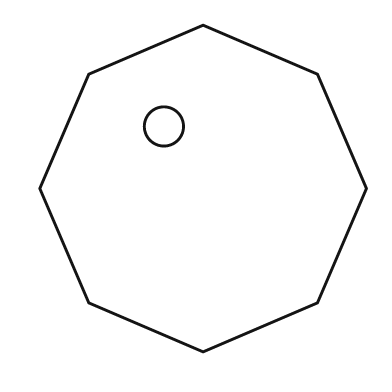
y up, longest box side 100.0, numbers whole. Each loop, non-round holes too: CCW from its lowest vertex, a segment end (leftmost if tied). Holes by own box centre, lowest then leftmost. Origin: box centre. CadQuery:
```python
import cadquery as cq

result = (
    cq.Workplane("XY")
    .moveTo(0.0, -50.0)
    .lineTo(35.0, -35.0)
    .lineTo(50.0, 0.0)
    .lineTo(35.0, 35.0)
    .lineTo(0.0, 50.0)
    .lineTo(-35.0, 35.0)
    .lineTo(-50.0, 0.0)
    .lineTo(-35.0, -35.0)
    .close()
    .moveTo(-12.0, 19.0)
    .circle(6.0)
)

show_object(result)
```